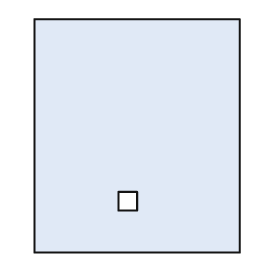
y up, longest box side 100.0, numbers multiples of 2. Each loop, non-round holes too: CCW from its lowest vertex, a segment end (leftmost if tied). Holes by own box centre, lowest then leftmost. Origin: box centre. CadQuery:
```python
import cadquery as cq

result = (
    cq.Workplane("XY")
    .moveTo(-44.0, -50.0)
    .lineTo(44.0, -50.0)
    .lineTo(44.0, 50.0)
    .lineTo(-44.0, 50.0)
    .close()
    .moveTo(-8.0, -32.0)
    .lineTo(0.0, -32.0)
    .lineTo(0.0, -24.0)
    .lineTo(-8.0, -24.0)
    .close()
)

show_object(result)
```